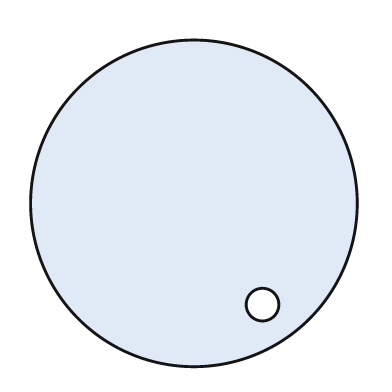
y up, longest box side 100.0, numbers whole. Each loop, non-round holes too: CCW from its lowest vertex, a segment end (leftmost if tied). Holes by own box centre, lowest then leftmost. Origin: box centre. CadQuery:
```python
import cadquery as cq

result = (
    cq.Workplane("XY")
    .moveTo(0.0, 0.0)
    .circle(50.0)
    .moveTo(21.0, -31.0)
    .circle(5.0)
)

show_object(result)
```